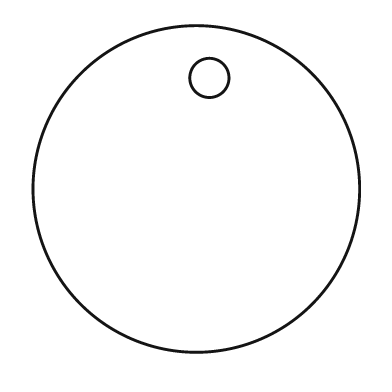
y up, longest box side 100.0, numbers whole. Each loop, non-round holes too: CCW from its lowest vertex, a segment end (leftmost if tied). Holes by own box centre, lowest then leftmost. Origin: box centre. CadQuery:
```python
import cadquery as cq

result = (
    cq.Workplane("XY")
    .moveTo(0.0, 0.0)
    .circle(50.0)
    .moveTo(4.0, 34.0)
    .circle(6.0)
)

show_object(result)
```